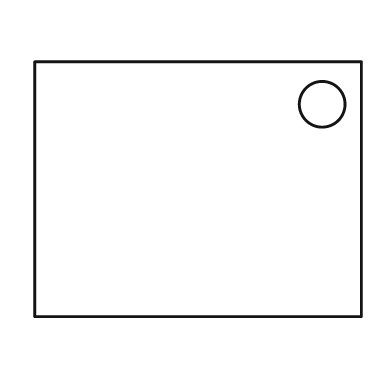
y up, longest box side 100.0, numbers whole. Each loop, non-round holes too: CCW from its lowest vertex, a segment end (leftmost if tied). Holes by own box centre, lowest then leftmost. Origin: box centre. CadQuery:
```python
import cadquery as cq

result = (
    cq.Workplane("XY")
    .moveTo(-50.0, -39.0)
    .lineTo(50.0, -39.0)
    .lineTo(50.0, 39.0)
    .lineTo(-50.0, 39.0)
    .close()
    .moveTo(38.0, 26.0)
    .circle(7.0)
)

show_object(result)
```